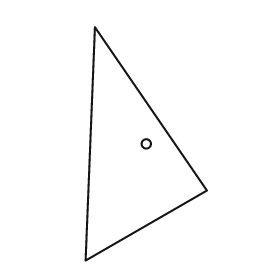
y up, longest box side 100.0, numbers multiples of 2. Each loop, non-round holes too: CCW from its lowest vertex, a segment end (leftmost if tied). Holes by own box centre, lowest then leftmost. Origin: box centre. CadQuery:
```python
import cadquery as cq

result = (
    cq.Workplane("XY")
    .moveTo(-26.0, -50.0)
    .lineTo(26.0, -20.0)
    .lineTo(-22.0, 50.0)
    .close()
    .moveTo(0.0, 0.0)
    .circle(2.0)
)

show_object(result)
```